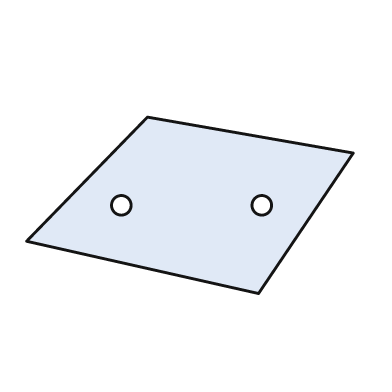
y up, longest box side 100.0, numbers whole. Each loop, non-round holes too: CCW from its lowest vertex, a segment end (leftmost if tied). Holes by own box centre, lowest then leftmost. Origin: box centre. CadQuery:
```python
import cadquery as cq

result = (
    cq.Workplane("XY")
    .moveTo(21.0, -27.0)
    .lineTo(50.0, 16.0)
    .lineTo(-13.0, 27.0)
    .lineTo(-50.0, -11.0)
    .close()
    .moveTo(-21.0, 0.0)
    .circle(3.0)
    .moveTo(22.0, 0.0)
    .circle(3.0)
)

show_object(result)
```